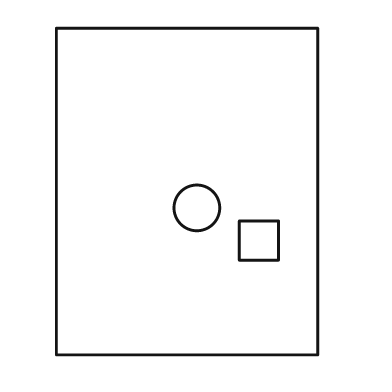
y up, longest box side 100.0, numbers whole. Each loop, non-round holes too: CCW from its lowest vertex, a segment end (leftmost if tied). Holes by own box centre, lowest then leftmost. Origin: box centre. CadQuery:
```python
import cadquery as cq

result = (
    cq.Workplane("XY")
    .moveTo(-40.0, -50.0)
    .lineTo(40.0, -50.0)
    .lineTo(40.0, 50.0)
    .lineTo(-40.0, 50.0)
    .close()
    .moveTo(16.0, -21.0)
    .lineTo(28.0, -21.0)
    .lineTo(28.0, -9.0)
    .lineTo(16.0, -9.0)
    .close()
    .moveTo(3.0, -5.0)
    .circle(7.0)
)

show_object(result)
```